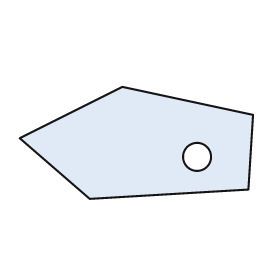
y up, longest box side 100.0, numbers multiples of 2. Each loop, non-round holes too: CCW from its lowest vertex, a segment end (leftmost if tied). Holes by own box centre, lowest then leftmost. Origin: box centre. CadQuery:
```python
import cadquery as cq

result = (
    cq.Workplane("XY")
    .moveTo(-20.0, -24.0)
    .lineTo(48.0, -20.0)
    .lineTo(50.0, 12.0)
    .lineTo(-6.0, 24.0)
    .lineTo(-50.0, 2.0)
    .close()
    .moveTo(26.0, -6.0)
    .circle(6.0)
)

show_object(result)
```